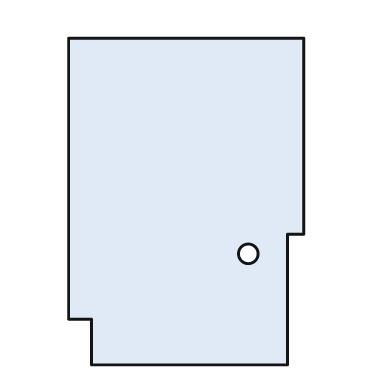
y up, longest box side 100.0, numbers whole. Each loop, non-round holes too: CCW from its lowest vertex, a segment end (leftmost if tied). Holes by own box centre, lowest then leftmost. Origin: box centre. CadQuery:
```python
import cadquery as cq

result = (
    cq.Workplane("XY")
    .moveTo(-29.0, -50.0)
    .lineTo(31.0, -50.0)
    .lineTo(31.0, -10.0)
    .lineTo(36.0, -10.0)
    .lineTo(36.0, 50.0)
    .lineTo(-36.0, 50.0)
    .lineTo(-36.0, -36.0)
    .lineTo(-29.0, -36.0)
    .close()
    .moveTo(19.0, -16.0)
    .circle(3.0)
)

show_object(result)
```